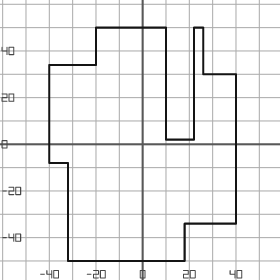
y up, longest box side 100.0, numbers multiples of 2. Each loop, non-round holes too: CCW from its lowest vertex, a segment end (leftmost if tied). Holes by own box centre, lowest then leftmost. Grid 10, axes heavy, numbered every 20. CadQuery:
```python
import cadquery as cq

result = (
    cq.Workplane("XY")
    .moveTo(-32.0, -50.0)
    .lineTo(18.0, -50.0)
    .lineTo(18.0, -34.0)
    .lineTo(40.0, -34.0)
    .lineTo(40.0, 30.0)
    .lineTo(26.0, 30.0)
    .lineTo(26.0, 50.0)
    .lineTo(22.0, 50.0)
    .lineTo(22.0, 2.0)
    .lineTo(10.0, 2.0)
    .lineTo(10.0, 50.0)
    .lineTo(-20.0, 50.0)
    .lineTo(-20.0, 34.0)
    .lineTo(-40.0, 34.0)
    .lineTo(-40.0, -8.0)
    .lineTo(-32.0, -8.0)
    .close()
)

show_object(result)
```